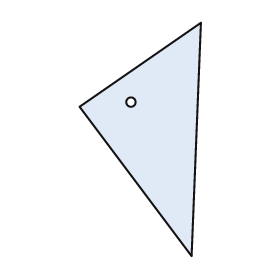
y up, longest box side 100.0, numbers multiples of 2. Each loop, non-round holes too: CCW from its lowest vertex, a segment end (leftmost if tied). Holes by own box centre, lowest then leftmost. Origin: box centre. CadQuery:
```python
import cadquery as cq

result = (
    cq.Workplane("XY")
    .moveTo(22.0, -50.0)
    .lineTo(26.0, 50.0)
    .lineTo(-26.0, 14.0)
    .close()
    .moveTo(-4.0, 16.0)
    .circle(2.0)
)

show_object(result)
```